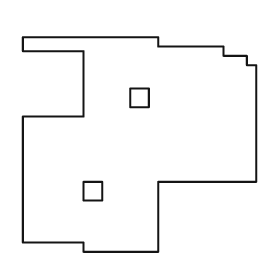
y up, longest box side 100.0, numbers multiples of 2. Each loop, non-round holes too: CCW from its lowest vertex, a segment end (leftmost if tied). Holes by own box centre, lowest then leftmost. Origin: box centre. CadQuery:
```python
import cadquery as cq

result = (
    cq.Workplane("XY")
    .moveTo(-24.0, -46.0)
    .lineTo(8.0, -46.0)
    .lineTo(8.0, -16.0)
    .lineTo(50.0, -16.0)
    .lineTo(50.0, 34.0)
    .lineTo(46.0, 34.0)
    .lineTo(46.0, 38.0)
    .lineTo(36.0, 38.0)
    .lineTo(36.0, 42.0)
    .lineTo(8.0, 42.0)
    .lineTo(8.0, 46.0)
    .lineTo(-50.0, 46.0)
    .lineTo(-50.0, 40.0)
    .lineTo(-24.0, 40.0)
    .lineTo(-24.0, 12.0)
    .lineTo(-50.0, 12.0)
    .lineTo(-50.0, -42.0)
    .lineTo(-24.0, -42.0)
    .close()
    .moveTo(-24.0, -24.0)
    .lineTo(-16.0, -24.0)
    .lineTo(-16.0, -16.0)
    .lineTo(-24.0, -16.0)
    .close()
    .moveTo(-4.0, 16.0)
    .lineTo(4.0, 16.0)
    .lineTo(4.0, 24.0)
    .lineTo(-4.0, 24.0)
    .close()
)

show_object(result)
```